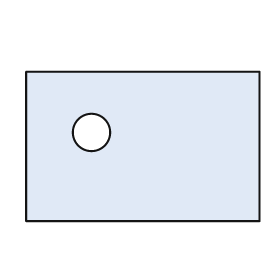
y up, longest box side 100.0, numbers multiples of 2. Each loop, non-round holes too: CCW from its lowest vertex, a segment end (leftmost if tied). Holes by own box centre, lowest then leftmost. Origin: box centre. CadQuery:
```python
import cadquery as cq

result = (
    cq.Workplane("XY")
    .moveTo(-50.0, -32.0)
    .lineTo(50.0, -32.0)
    .lineTo(50.0, 32.0)
    .lineTo(-50.0, 32.0)
    .close()
    .moveTo(-22.0, 6.0)
    .circle(8.0)
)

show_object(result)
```